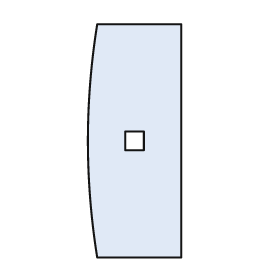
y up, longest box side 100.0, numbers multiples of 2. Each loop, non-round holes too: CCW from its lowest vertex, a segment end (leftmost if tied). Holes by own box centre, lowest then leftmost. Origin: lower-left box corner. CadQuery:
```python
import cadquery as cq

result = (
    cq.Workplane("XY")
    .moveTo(4.0, 0.0)
    .lineTo(40.0, 0.0)
    .lineTo(40.0, 100.0)
    .lineTo(4.0, 100.0)
    .threePointArc((0.0, 50.0), (4.0, 0.0))
    .close()
    .moveTo(16.0, 46.0)
    .lineTo(24.0, 46.0)
    .lineTo(24.0, 54.0)
    .lineTo(16.0, 54.0)
    .close()
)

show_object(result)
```